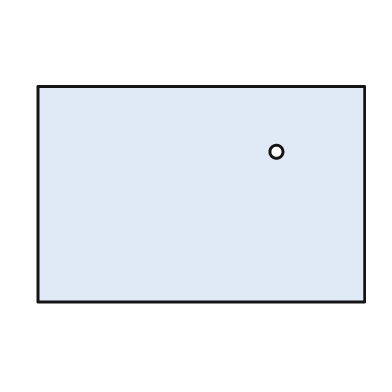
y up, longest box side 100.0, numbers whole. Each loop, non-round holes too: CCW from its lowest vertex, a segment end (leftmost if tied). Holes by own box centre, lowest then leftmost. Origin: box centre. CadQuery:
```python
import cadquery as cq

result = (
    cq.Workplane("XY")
    .moveTo(-50.0, -33.0)
    .lineTo(50.0, -33.0)
    .lineTo(50.0, 33.0)
    .lineTo(-50.0, 33.0)
    .close()
    .moveTo(23.0, 13.0)
    .circle(2.0)
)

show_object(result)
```